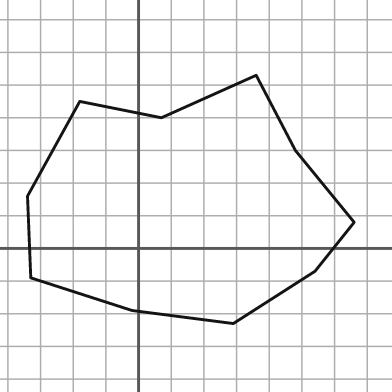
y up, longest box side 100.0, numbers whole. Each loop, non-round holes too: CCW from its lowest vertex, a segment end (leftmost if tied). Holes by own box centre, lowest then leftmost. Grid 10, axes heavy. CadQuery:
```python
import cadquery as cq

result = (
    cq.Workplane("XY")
    .moveTo(29.0, -23.0)
    .lineTo(54.0, -7.0)
    .lineTo(66.0, 8.0)
    .lineTo(48.0, 30.0)
    .lineTo(36.0, 53.0)
    .lineTo(7.0, 40.0)
    .lineTo(-18.0, 45.0)
    .lineTo(-34.0, 16.0)
    .lineTo(-33.0, -9.0)
    .lineTo(-2.0, -19.0)
    .close()
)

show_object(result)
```